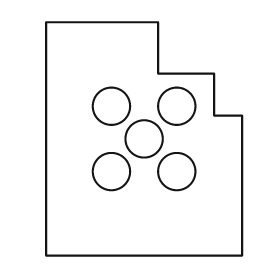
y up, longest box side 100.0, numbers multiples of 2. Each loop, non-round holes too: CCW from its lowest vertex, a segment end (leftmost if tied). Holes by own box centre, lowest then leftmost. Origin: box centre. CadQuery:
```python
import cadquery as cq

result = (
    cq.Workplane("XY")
    .moveTo(-42.0, -50.0)
    .lineTo(42.0, -50.0)
    .lineTo(42.0, 10.0)
    .lineTo(30.0, 10.0)
    .lineTo(30.0, 28.0)
    .lineTo(6.0, 28.0)
    .lineTo(6.0, 50.0)
    .lineTo(-42.0, 50.0)
    .close()
    .moveTo(-14.0, -14.0)
    .circle(8.0)
    .moveTo(14.0, -14.0)
    .circle(8.0)
    .moveTo(0.0, 0.0)
    .circle(8.0)
    .moveTo(-14.0, 14.0)
    .circle(8.0)
    .moveTo(14.0, 14.0)
    .circle(8.0)
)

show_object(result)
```